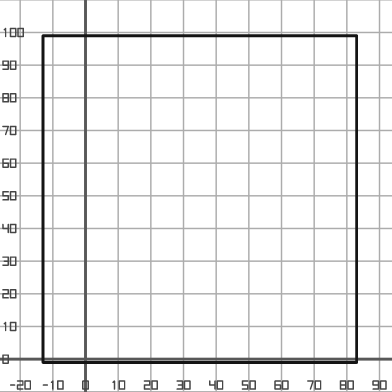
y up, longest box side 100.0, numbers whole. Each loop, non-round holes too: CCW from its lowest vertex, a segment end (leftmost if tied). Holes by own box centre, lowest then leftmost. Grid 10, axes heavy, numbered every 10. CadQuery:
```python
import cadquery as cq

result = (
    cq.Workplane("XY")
    .moveTo(-13.0, -1.0)
    .lineTo(83.0, -1.0)
    .lineTo(83.0, 99.0)
    .lineTo(-13.0, 99.0)
    .close()
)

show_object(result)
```